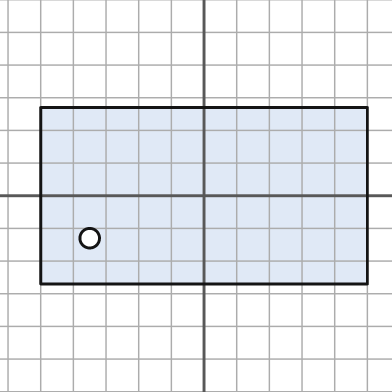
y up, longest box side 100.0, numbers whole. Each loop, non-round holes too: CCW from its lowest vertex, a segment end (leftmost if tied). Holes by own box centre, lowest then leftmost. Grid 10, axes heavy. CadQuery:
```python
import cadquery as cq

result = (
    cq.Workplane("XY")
    .moveTo(-50.0, -27.0)
    .lineTo(50.0, -27.0)
    .lineTo(50.0, 27.0)
    .lineTo(-50.0, 27.0)
    .close()
    .moveTo(-35.0, -13.0)
    .circle(3.0)
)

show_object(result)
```